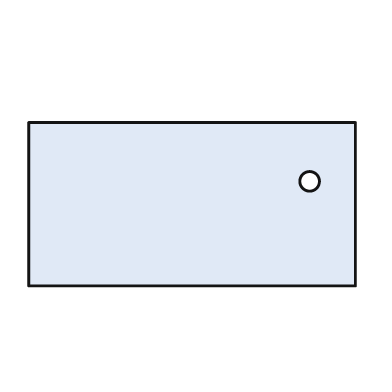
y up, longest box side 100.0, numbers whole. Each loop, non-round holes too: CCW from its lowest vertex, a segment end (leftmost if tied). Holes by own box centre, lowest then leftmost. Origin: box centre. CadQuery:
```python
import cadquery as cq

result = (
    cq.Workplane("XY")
    .moveTo(-50.0, -25.0)
    .lineTo(50.0, -25.0)
    .lineTo(50.0, 25.0)
    .lineTo(-50.0, 25.0)
    .close()
    .moveTo(36.0, 7.0)
    .circle(3.0)
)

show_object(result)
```